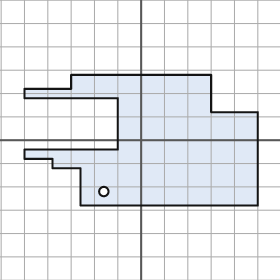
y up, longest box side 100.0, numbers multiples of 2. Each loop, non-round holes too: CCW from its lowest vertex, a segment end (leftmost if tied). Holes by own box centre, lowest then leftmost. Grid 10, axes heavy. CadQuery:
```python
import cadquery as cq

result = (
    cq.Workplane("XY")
    .moveTo(-26.0, -28.0)
    .lineTo(50.0, -28.0)
    .lineTo(50.0, 12.0)
    .lineTo(30.0, 12.0)
    .lineTo(30.0, 28.0)
    .lineTo(-30.0, 28.0)
    .lineTo(-30.0, 22.0)
    .lineTo(-50.0, 22.0)
    .lineTo(-50.0, 18.0)
    .lineTo(-10.0, 18.0)
    .lineTo(-10.0, -4.0)
    .lineTo(-50.0, -4.0)
    .lineTo(-50.0, -8.0)
    .lineTo(-38.0, -8.0)
    .lineTo(-38.0, -12.0)
    .lineTo(-26.0, -12.0)
    .close()
    .moveTo(-16.0, -22.0)
    .circle(2.0)
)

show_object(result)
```